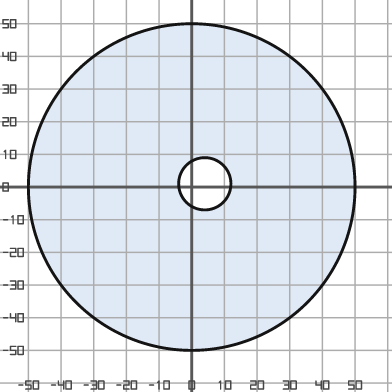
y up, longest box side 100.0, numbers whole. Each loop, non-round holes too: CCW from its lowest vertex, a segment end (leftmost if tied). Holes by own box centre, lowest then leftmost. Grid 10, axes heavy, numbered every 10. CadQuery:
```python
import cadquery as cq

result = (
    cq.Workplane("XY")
    .moveTo(0.0, 0.0)
    .circle(50.0)
    .moveTo(4.0, 1.0)
    .circle(8.0)
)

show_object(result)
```